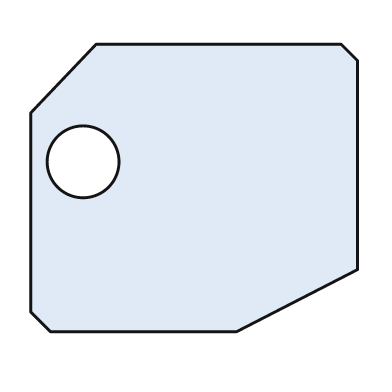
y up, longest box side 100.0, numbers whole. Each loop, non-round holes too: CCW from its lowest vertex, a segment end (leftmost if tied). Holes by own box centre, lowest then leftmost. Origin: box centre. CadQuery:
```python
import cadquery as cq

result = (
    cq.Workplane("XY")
    .moveTo(-44.0, -44.0)
    .lineTo(13.0, -44.0)
    .lineTo(50.0, -25.0)
    .lineTo(50.0, 39.0)
    .lineTo(45.0, 44.0)
    .lineTo(-30.0, 44.0)
    .lineTo(-50.0, 23.0)
    .lineTo(-50.0, -38.0)
    .close()
    .moveTo(-34.0, 8.0)
    .circle(11.0)
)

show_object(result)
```